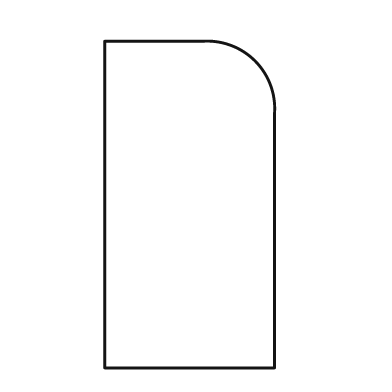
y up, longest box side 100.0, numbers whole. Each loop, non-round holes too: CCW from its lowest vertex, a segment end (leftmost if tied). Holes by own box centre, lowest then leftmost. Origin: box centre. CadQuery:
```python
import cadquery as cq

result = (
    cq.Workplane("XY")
    .moveTo(-26.0, -50.0)
    .lineTo(26.0, -50.0)
    .lineTo(26.0, 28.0)
    .threePointArc((20.0, 44.0), (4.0, 50.0))
    .lineTo(-26.0, 50.0)
    .close()
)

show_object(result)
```